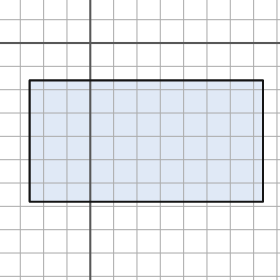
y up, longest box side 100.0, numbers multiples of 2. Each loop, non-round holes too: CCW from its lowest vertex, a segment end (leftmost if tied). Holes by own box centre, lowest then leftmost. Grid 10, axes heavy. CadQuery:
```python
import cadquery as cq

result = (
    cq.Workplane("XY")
    .moveTo(-26.0, -68.0)
    .lineTo(74.0, -68.0)
    .lineTo(74.0, -16.0)
    .lineTo(-26.0, -16.0)
    .close()
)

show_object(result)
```